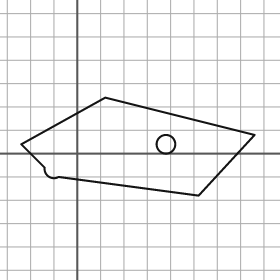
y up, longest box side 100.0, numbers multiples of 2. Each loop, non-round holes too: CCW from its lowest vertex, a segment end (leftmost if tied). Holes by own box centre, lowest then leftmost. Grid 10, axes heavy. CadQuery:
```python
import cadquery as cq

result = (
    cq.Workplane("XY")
    .moveTo(52.0, -18.0)
    .lineTo(76.0, 8.0)
    .lineTo(12.0, 24.0)
    .lineTo(-24.0, 4.0)
    .lineTo(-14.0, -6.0)
    .threePointArc((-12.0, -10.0), (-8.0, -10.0))
    .close()
    .moveTo(38.0, 4.0)
    .circle(4.0)
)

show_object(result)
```